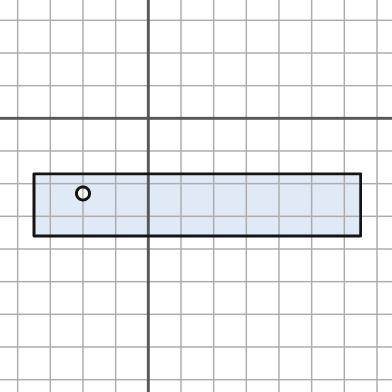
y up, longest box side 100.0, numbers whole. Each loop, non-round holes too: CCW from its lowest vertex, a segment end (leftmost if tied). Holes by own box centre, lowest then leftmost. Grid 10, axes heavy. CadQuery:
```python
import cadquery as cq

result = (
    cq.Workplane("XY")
    .moveTo(-35.0, -36.0)
    .lineTo(65.0, -36.0)
    .lineTo(65.0, -17.0)
    .lineTo(-35.0, -17.0)
    .close()
    .moveTo(-20.0, -23.0)
    .circle(2.0)
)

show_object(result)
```